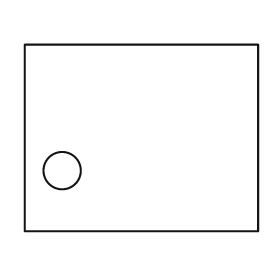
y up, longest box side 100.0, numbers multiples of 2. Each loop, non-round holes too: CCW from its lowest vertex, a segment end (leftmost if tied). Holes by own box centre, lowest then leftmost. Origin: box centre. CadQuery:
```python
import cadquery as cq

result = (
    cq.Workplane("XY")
    .moveTo(-50.0, -40.0)
    .lineTo(50.0, -40.0)
    .lineTo(50.0, 40.0)
    .lineTo(-50.0, 40.0)
    .close()
    .moveTo(-34.0, -14.0)
    .circle(8.0)
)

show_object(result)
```